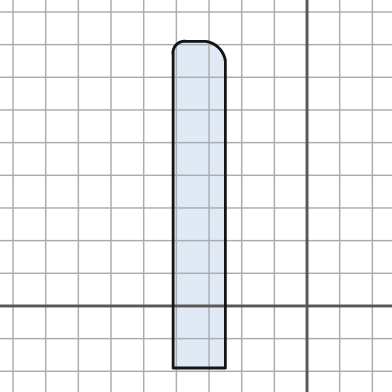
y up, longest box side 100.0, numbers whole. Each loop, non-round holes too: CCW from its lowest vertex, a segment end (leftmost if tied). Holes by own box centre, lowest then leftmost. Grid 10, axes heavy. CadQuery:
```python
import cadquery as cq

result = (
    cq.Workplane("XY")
    .moveTo(-41.0, -19.0)
    .lineTo(-25.0, -19.0)
    .lineTo(-25.0, 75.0)
    .threePointArc((-27.0, 79.0), (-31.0, 81.0))
    .lineTo(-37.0, 81.0)
    .threePointArc((-40.0, 80.0), (-41.0, 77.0))
    .close()
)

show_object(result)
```